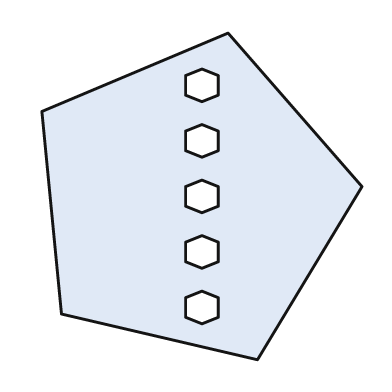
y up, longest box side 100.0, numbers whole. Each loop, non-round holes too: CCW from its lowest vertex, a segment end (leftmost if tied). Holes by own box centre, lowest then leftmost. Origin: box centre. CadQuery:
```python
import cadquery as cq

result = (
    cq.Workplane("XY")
    .moveTo(17.0, -50.0)
    .lineTo(49.0, 3.0)
    .lineTo(8.0, 50.0)
    .lineTo(-49.0, 26.0)
    .lineTo(-43.0, -36.0)
    .close()
    .moveTo(0.0, -39.0)
    .lineTo(5.0, -37.0)
    .lineTo(5.0, -31.0)
    .lineTo(0.0, -29.0)
    .lineTo(-5.0, -31.0)
    .lineTo(-5.0, -37.0)
    .close()
    .moveTo(0.0, -22.0)
    .lineTo(5.0, -20.0)
    .lineTo(5.0, -14.0)
    .lineTo(0.0, -12.0)
    .lineTo(-5.0, -14.0)
    .lineTo(-5.0, -20.0)
    .close()
    .moveTo(0.0, -5.0)
    .lineTo(5.0, -3.0)
    .lineTo(5.0, 3.0)
    .lineTo(0.0, 5.0)
    .lineTo(-5.0, 3.0)
    .lineTo(-5.0, -3.0)
    .close()
    .moveTo(0.0, 12.0)
    .lineTo(5.0, 14.0)
    .lineTo(5.0, 20.0)
    .lineTo(0.0, 22.0)
    .lineTo(-5.0, 20.0)
    .lineTo(-5.0, 14.0)
    .close()
    .moveTo(0.0, 29.0)
    .lineTo(5.0, 31.0)
    .lineTo(5.0, 37.0)
    .lineTo(0.0, 39.0)
    .lineTo(-5.0, 37.0)
    .lineTo(-5.0, 31.0)
    .close()
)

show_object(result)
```